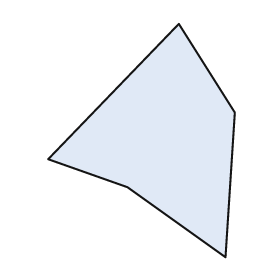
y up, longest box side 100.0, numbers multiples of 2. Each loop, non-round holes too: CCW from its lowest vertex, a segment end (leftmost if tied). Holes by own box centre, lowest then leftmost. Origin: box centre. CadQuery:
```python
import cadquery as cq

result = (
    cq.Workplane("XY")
    .moveTo(36.0, -50.0)
    .lineTo(40.0, 12.0)
    .lineTo(16.0, 50.0)
    .lineTo(-40.0, -8.0)
    .lineTo(-6.0, -20.0)
    .close()
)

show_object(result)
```